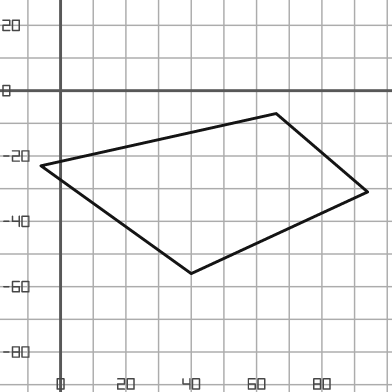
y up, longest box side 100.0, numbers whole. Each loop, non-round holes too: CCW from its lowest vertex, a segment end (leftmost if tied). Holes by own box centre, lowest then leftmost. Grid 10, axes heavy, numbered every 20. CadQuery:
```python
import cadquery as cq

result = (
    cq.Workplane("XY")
    .moveTo(40.0, -56.0)
    .lineTo(94.0, -31.0)
    .lineTo(66.0, -7.0)
    .lineTo(-6.0, -23.0)
    .close()
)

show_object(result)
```